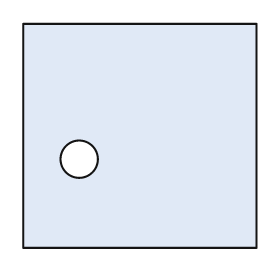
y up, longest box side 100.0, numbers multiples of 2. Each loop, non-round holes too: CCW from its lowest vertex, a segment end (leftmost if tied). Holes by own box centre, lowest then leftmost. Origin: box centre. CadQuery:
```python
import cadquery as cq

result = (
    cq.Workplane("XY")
    .moveTo(-50.0, -48.0)
    .lineTo(50.0, -48.0)
    .lineTo(50.0, 48.0)
    .lineTo(-50.0, 48.0)
    .close()
    .moveTo(-26.0, -10.0)
    .circle(8.0)
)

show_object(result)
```